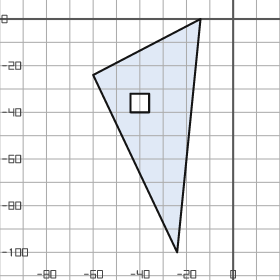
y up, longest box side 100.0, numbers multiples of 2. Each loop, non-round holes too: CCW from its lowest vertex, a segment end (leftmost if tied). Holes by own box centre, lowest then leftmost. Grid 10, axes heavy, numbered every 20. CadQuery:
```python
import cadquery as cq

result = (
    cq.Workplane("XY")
    .moveTo(-24.0, -100.0)
    .lineTo(-14.0, 0.0)
    .lineTo(-60.0, -24.0)
    .close()
    .moveTo(-44.0, -40.0)
    .lineTo(-36.0, -40.0)
    .lineTo(-36.0, -32.0)
    .lineTo(-44.0, -32.0)
    .close()
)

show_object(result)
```